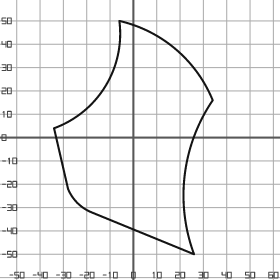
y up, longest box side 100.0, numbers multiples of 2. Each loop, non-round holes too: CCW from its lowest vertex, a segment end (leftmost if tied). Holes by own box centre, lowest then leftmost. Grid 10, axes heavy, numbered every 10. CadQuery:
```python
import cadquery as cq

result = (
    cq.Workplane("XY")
    .moveTo(26.0, -50.0)
    .threePointArc((22.0, -16.0), (34.0, 16.0))
    .threePointArc((18.0, 38.0), (-6.0, 50.0))
    .threePointArc((-12.0, 22.0), (-34.0, 4.0))
    .lineTo(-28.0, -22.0)
    .threePointArc((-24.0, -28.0), (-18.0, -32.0))
    .close()
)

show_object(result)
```